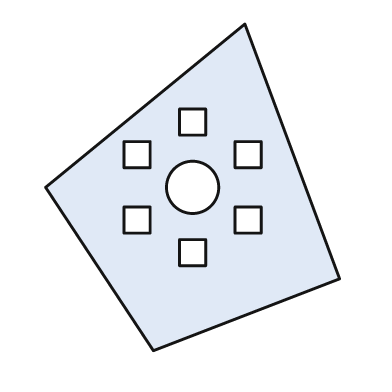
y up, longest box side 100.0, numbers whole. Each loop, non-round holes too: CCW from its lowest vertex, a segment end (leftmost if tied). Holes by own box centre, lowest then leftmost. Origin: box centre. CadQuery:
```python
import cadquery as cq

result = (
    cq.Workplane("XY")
    .moveTo(-12.0, -50.0)
    .lineTo(45.0, -28.0)
    .lineTo(16.0, 50.0)
    .lineTo(-45.0, 0.0)
    .close()
    .moveTo(-4.0, -24.0)
    .lineTo(4.0, -24.0)
    .lineTo(4.0, -16.0)
    .lineTo(-4.0, -16.0)
    .close()
    .moveTo(-21.0, -14.0)
    .lineTo(-13.0, -14.0)
    .lineTo(-13.0, -6.0)
    .lineTo(-21.0, -6.0)
    .close()
    .moveTo(13.0, -14.0)
    .lineTo(21.0, -14.0)
    .lineTo(21.0, -6.0)
    .lineTo(13.0, -6.0)
    .close()
    .moveTo(0.0, 0.0)
    .circle(8.0)
    .moveTo(-21.0, 6.0)
    .lineTo(-13.0, 6.0)
    .lineTo(-13.0, 14.0)
    .lineTo(-21.0, 14.0)
    .close()
    .moveTo(13.0, 6.0)
    .lineTo(21.0, 6.0)
    .lineTo(21.0, 14.0)
    .lineTo(13.0, 14.0)
    .close()
    .moveTo(-4.0, 16.0)
    .lineTo(4.0, 16.0)
    .lineTo(4.0, 24.0)
    .lineTo(-4.0, 24.0)
    .close()
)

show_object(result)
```